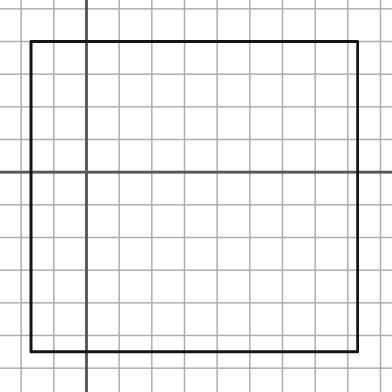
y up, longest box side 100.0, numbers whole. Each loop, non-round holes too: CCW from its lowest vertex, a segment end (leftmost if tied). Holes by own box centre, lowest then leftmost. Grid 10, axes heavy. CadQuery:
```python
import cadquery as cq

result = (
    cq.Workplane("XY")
    .moveTo(-17.0, -55.0)
    .lineTo(83.0, -55.0)
    .lineTo(83.0, 40.0)
    .lineTo(-17.0, 40.0)
    .close()
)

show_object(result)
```